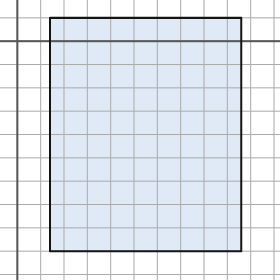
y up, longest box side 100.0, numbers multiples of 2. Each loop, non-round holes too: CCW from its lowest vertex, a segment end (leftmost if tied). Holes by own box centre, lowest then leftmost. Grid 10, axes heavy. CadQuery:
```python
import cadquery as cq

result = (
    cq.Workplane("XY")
    .moveTo(14.0, -90.0)
    .lineTo(96.0, -90.0)
    .lineTo(96.0, 10.0)
    .lineTo(14.0, 10.0)
    .close()
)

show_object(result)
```